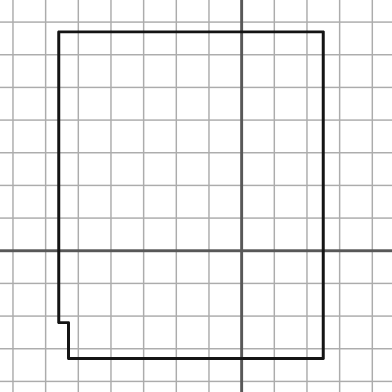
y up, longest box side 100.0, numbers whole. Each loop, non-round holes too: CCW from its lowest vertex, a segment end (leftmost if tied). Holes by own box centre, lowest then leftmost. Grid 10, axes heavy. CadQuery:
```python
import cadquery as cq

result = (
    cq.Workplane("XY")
    .moveTo(-53.0, -33.0)
    .lineTo(25.0, -33.0)
    .lineTo(25.0, 67.0)
    .lineTo(-56.0, 67.0)
    .lineTo(-56.0, -22.0)
    .lineTo(-53.0, -22.0)
    .close()
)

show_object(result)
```